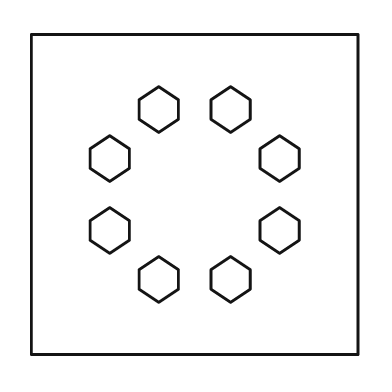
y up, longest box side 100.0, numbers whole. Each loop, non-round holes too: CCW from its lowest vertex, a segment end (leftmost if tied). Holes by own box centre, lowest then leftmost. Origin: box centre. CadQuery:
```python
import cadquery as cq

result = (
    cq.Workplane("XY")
    .moveTo(-50.0, -49.0)
    .lineTo(50.0, -49.0)
    .lineTo(50.0, 49.0)
    .lineTo(-50.0, 49.0)
    .close()
    .moveTo(-11.0, -33.0)
    .lineTo(-5.0, -29.0)
    .lineTo(-5.0, -23.0)
    .lineTo(-11.0, -19.0)
    .lineTo(-17.0, -23.0)
    .lineTo(-17.0, -29.0)
    .close()
    .moveTo(11.0, -33.0)
    .lineTo(17.0, -29.0)
    .lineTo(17.0, -23.0)
    .lineTo(11.0, -19.0)
    .lineTo(5.0, -23.0)
    .lineTo(5.0, -29.0)
    .close()
    .moveTo(-26.0, -18.0)
    .lineTo(-20.0, -14.0)
    .lineTo(-20.0, -8.0)
    .lineTo(-26.0, -4.0)
    .lineTo(-32.0, -8.0)
    .lineTo(-32.0, -14.0)
    .close()
    .moveTo(26.0, -18.0)
    .lineTo(32.0, -14.0)
    .lineTo(32.0, -8.0)
    .lineTo(26.0, -4.0)
    .lineTo(20.0, -8.0)
    .lineTo(20.0, -14.0)
    .close()
    .moveTo(-26.0, 4.0)
    .lineTo(-20.0, 8.0)
    .lineTo(-20.0, 14.0)
    .lineTo(-26.0, 18.0)
    .lineTo(-32.0, 14.0)
    .lineTo(-32.0, 8.0)
    .close()
    .moveTo(26.0, 4.0)
    .lineTo(32.0, 8.0)
    .lineTo(32.0, 14.0)
    .lineTo(26.0, 18.0)
    .lineTo(20.0, 14.0)
    .lineTo(20.0, 8.0)
    .close()
    .moveTo(-11.0, 19.0)
    .lineTo(-5.0, 23.0)
    .lineTo(-5.0, 29.0)
    .lineTo(-11.0, 33.0)
    .lineTo(-17.0, 29.0)
    .lineTo(-17.0, 23.0)
    .close()
    .moveTo(11.0, 19.0)
    .lineTo(17.0, 23.0)
    .lineTo(17.0, 29.0)
    .lineTo(11.0, 33.0)
    .lineTo(5.0, 29.0)
    .lineTo(5.0, 23.0)
    .close()
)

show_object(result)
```